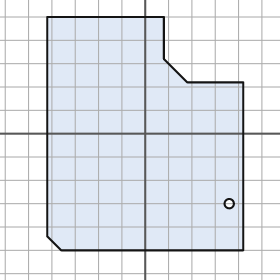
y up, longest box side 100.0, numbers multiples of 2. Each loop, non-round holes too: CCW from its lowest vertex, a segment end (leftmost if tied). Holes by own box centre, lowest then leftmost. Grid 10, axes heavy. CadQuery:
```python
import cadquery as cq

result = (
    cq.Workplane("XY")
    .moveTo(-36.0, -50.0)
    .lineTo(42.0, -50.0)
    .lineTo(42.0, 22.0)
    .lineTo(18.0, 22.0)
    .lineTo(8.0, 32.0)
    .lineTo(8.0, 50.0)
    .lineTo(-42.0, 50.0)
    .lineTo(-42.0, -44.0)
    .close()
    .moveTo(36.0, -30.0)
    .circle(2.0)
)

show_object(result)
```